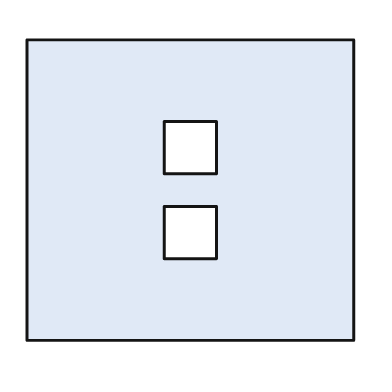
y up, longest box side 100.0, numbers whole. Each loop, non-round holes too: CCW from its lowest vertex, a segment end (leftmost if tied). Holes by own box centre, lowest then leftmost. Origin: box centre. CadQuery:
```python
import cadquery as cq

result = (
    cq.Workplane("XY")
    .moveTo(-50.0, -46.0)
    .lineTo(50.0, -46.0)
    .lineTo(50.0, 46.0)
    .lineTo(-50.0, 46.0)
    .close()
    .moveTo(-8.0, -21.0)
    .lineTo(8.0, -21.0)
    .lineTo(8.0, -5.0)
    .lineTo(-8.0, -5.0)
    .close()
    .moveTo(-8.0, 5.0)
    .lineTo(8.0, 5.0)
    .lineTo(8.0, 21.0)
    .lineTo(-8.0, 21.0)
    .close()
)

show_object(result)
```